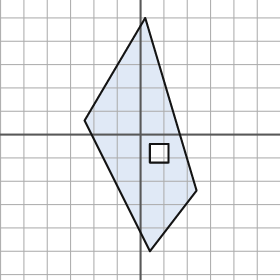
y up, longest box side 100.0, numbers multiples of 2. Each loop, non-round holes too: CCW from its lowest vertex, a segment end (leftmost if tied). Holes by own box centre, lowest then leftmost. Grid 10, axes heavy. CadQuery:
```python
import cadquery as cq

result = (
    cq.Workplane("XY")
    .moveTo(4.0, -50.0)
    .lineTo(24.0, -24.0)
    .lineTo(2.0, 50.0)
    .lineTo(-24.0, 6.0)
    .close()
    .moveTo(4.0, -12.0)
    .lineTo(12.0, -12.0)
    .lineTo(12.0, -4.0)
    .lineTo(4.0, -4.0)
    .close()
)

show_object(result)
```